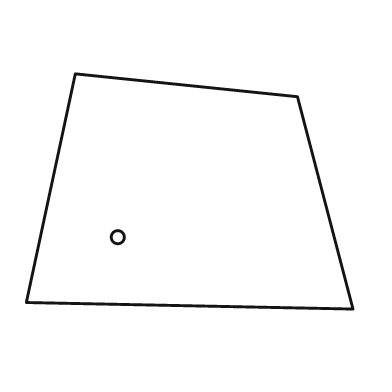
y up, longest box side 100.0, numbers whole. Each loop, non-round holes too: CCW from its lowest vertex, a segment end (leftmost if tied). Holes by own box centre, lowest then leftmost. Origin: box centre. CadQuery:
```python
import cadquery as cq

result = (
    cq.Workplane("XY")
    .moveTo(50.0, -36.0)
    .lineTo(33.0, 29.0)
    .lineTo(-35.0, 36.0)
    .lineTo(-50.0, -34.0)
    .close()
    .moveTo(-22.0, -14.0)
    .circle(2.0)
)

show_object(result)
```